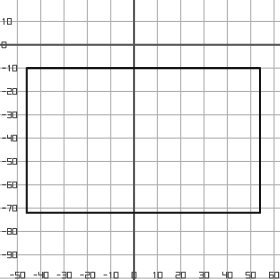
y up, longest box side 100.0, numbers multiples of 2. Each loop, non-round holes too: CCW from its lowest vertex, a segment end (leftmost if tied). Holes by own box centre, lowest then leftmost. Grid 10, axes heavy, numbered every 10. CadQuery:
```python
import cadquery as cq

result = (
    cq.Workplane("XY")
    .moveTo(-46.0, -72.0)
    .lineTo(54.0, -72.0)
    .lineTo(54.0, -10.0)
    .lineTo(-46.0, -10.0)
    .close()
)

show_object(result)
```